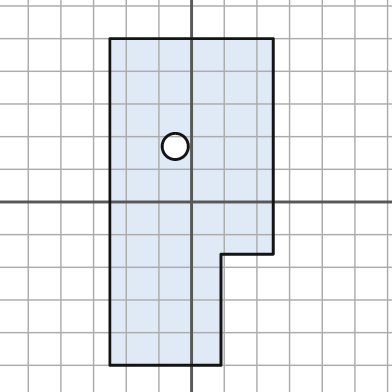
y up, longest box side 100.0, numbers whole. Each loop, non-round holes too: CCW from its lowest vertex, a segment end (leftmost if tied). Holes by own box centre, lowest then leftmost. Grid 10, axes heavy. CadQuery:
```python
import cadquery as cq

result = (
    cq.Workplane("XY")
    .moveTo(-25.0, -50.0)
    .lineTo(9.0, -50.0)
    .lineTo(9.0, -16.0)
    .lineTo(25.0, -16.0)
    .lineTo(25.0, 50.0)
    .lineTo(-25.0, 50.0)
    .close()
    .moveTo(-5.0, 17.0)
    .circle(4.0)
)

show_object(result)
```